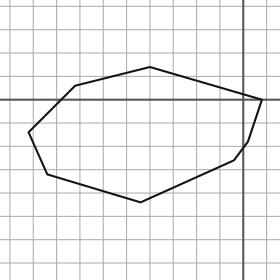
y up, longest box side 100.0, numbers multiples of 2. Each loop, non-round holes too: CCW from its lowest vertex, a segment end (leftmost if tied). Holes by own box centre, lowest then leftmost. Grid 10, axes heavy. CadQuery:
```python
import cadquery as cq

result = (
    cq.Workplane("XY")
    .moveTo(-44.0, -44.0)
    .lineTo(-4.0, -26.0)
    .lineTo(2.0, -18.0)
    .lineTo(8.0, 0.0)
    .lineTo(-40.0, 14.0)
    .lineTo(-72.0, 6.0)
    .lineTo(-92.0, -14.0)
    .lineTo(-84.0, -32.0)
    .close()
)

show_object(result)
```